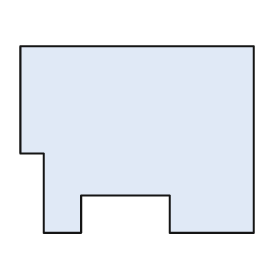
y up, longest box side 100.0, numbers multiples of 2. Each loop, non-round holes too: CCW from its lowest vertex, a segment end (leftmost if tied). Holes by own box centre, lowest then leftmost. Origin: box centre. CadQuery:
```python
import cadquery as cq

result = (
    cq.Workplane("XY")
    .moveTo(-40.0, -40.0)
    .lineTo(-24.0, -40.0)
    .lineTo(-24.0, -24.0)
    .lineTo(14.0, -24.0)
    .lineTo(14.0, -40.0)
    .lineTo(50.0, -40.0)
    .lineTo(50.0, 40.0)
    .lineTo(-50.0, 40.0)
    .lineTo(-50.0, -6.0)
    .lineTo(-40.0, -6.0)
    .close()
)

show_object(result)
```